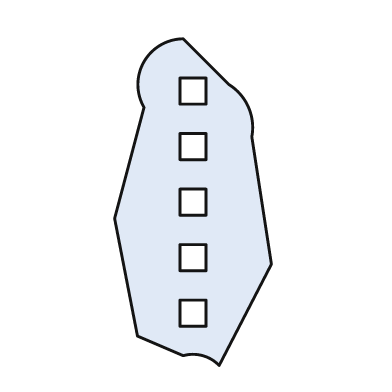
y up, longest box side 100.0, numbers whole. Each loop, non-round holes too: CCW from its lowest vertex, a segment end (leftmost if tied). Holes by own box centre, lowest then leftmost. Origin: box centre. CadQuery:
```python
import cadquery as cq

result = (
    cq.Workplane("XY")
    .moveTo(8.0, -50.0)
    .lineTo(24.0, -19.0)
    .lineTo(18.0, 20.0)
    .threePointArc((17.0, 29.0), (11.0, 36.0))
    .lineTo(-3.0, 50.0)
    .threePointArc((-15.0, 43.0), (-15.0, 29.0))
    .lineTo(-24.0, -5.0)
    .lineTo(-17.0, -41.0)
    .lineTo(-3.0, -47.0)
    .threePointArc((3.0, -47.0), (8.0, -50.0))
    .close()
    .moveTo(-4.0, -38.0)
    .lineTo(4.0, -38.0)
    .lineTo(4.0, -30.0)
    .lineTo(-4.0, -30.0)
    .close()
    .moveTo(-4.0, -21.0)
    .lineTo(4.0, -21.0)
    .lineTo(4.0, -13.0)
    .lineTo(-4.0, -13.0)
    .close()
    .moveTo(-4.0, -4.0)
    .lineTo(4.0, -4.0)
    .lineTo(4.0, 4.0)
    .lineTo(-4.0, 4.0)
    .close()
    .moveTo(-4.0, 13.0)
    .lineTo(4.0, 13.0)
    .lineTo(4.0, 21.0)
    .lineTo(-4.0, 21.0)
    .close()
    .moveTo(-4.0, 30.0)
    .lineTo(4.0, 30.0)
    .lineTo(4.0, 38.0)
    .lineTo(-4.0, 38.0)
    .close()
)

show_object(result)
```